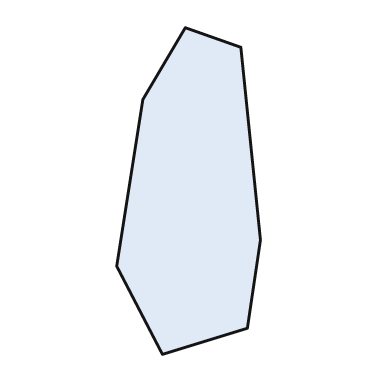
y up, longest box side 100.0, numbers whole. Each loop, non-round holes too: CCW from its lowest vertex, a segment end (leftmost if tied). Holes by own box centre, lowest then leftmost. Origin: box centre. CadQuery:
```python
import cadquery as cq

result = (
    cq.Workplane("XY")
    .moveTo(-8.0, -50.0)
    .lineTo(18.0, -42.0)
    .lineTo(22.0, -15.0)
    .lineTo(16.0, 44.0)
    .lineTo(-1.0, 50.0)
    .lineTo(-14.0, 28.0)
    .lineTo(-22.0, -23.0)
    .close()
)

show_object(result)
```